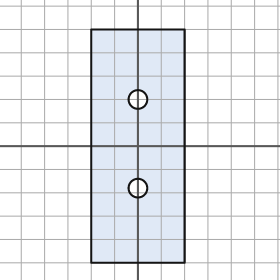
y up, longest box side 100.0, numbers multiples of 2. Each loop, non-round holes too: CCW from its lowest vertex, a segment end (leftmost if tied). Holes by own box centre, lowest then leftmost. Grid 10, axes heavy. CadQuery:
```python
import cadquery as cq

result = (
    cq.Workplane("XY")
    .moveTo(-20.0, -50.0)
    .lineTo(20.0, -50.0)
    .lineTo(20.0, 50.0)
    .lineTo(-20.0, 50.0)
    .close()
    .moveTo(0.0, -18.0)
    .circle(4.0)
    .moveTo(0.0, 20.0)
    .circle(4.0)
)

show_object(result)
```